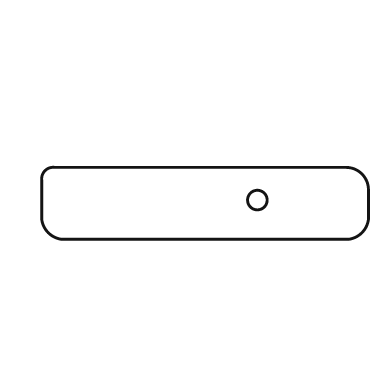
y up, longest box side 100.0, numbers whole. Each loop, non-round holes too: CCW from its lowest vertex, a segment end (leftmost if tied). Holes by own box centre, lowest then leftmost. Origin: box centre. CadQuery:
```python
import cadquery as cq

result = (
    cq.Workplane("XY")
    .moveTo(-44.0, -11.0)
    .lineTo(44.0, -11.0)
    .threePointArc((48.0, -9.0), (50.0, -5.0))
    .lineTo(50.0, 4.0)
    .threePointArc((48.0, 9.0), (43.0, 11.0))
    .lineTo(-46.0, 11.0)
    .threePointArc((-49.0, 10.0), (-50.0, 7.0))
    .lineTo(-50.0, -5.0)
    .threePointArc((-48.0, -9.0), (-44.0, -11.0))
    .close()
    .moveTo(16.0, 1.0)
    .circle(3.0)
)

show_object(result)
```